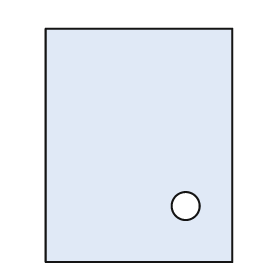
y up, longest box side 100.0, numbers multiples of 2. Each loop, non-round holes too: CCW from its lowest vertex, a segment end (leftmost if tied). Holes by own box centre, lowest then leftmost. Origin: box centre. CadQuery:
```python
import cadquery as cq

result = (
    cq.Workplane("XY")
    .moveTo(-40.0, -50.0)
    .lineTo(40.0, -50.0)
    .lineTo(40.0, 50.0)
    .lineTo(-40.0, 50.0)
    .close()
    .moveTo(20.0, -26.0)
    .circle(6.0)
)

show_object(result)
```